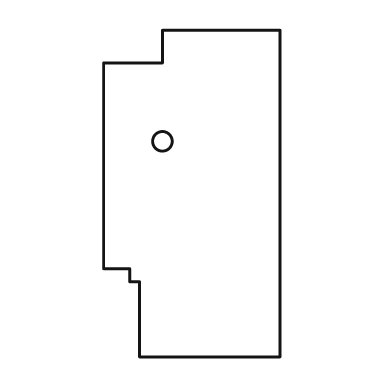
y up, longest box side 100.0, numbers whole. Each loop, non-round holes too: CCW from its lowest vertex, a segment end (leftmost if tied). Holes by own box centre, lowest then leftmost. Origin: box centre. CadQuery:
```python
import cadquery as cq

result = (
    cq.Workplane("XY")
    .moveTo(-16.0, -50.0)
    .lineTo(27.0, -50.0)
    .lineTo(27.0, 50.0)
    .lineTo(-9.0, 50.0)
    .lineTo(-9.0, 40.0)
    .lineTo(-27.0, 40.0)
    .lineTo(-27.0, -23.0)
    .lineTo(-19.0, -23.0)
    .lineTo(-19.0, -27.0)
    .lineTo(-16.0, -27.0)
    .close()
    .moveTo(-9.0, 16.0)
    .circle(3.0)
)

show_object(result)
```